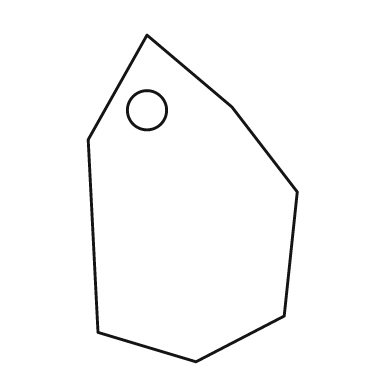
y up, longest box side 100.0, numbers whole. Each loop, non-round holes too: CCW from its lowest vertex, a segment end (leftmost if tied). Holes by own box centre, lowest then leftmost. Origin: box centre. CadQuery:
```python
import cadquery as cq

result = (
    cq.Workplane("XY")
    .moveTo(1.0, -50.0)
    .lineTo(28.0, -36.0)
    .lineTo(32.0, 2.0)
    .lineTo(12.0, 28.0)
    .lineTo(-14.0, 50.0)
    .lineTo(-32.0, 18.0)
    .lineTo(-29.0, -41.0)
    .close()
    .moveTo(-14.0, 27.0)
    .circle(6.0)
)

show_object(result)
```